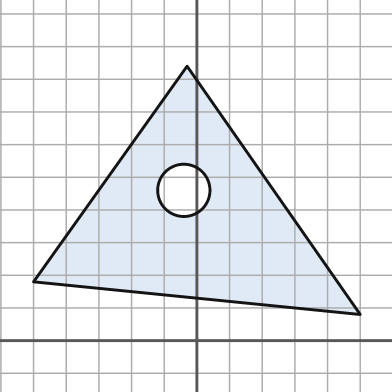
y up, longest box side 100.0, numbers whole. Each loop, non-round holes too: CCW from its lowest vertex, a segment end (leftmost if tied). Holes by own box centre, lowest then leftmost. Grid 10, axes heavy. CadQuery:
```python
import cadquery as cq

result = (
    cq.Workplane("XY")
    .moveTo(50.0, 8.0)
    .lineTo(-3.0, 84.0)
    .lineTo(-50.0, 18.0)
    .close()
    .moveTo(-4.0, 46.0)
    .circle(8.0)
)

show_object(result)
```